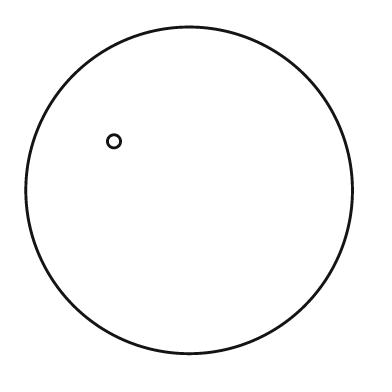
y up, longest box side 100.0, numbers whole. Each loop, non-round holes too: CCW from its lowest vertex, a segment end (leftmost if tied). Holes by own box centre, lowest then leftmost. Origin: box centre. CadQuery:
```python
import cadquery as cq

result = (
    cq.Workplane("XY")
    .moveTo(0.0, 0.0)
    .circle(50.0)
    .moveTo(-23.0, 15.0)
    .circle(2.0)
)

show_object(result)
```